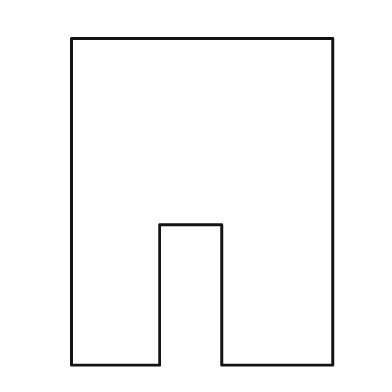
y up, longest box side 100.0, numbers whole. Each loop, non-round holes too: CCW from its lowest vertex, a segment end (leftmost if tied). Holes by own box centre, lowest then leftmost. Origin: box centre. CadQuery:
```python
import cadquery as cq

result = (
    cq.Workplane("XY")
    .moveTo(-40.0, -50.0)
    .lineTo(-13.0, -50.0)
    .lineTo(-13.0, -7.0)
    .lineTo(6.0, -7.0)
    .lineTo(6.0, -50.0)
    .lineTo(40.0, -50.0)
    .lineTo(40.0, 50.0)
    .lineTo(-40.0, 50.0)
    .close()
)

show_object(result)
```